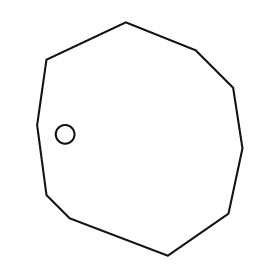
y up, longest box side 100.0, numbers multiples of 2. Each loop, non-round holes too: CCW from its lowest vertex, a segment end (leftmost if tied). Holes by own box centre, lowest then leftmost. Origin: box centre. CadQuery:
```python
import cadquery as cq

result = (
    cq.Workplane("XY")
    .moveTo(12.0, -50.0)
    .lineTo(38.0, -32.0)
    .lineTo(44.0, -4.0)
    .lineTo(40.0, 22.0)
    .lineTo(24.0, 38.0)
    .lineTo(-6.0, 50.0)
    .lineTo(-40.0, 34.0)
    .lineTo(-44.0, 6.0)
    .lineTo(-40.0, -24.0)
    .lineTo(-30.0, -34.0)
    .close()
    .moveTo(-32.0, 2.0)
    .circle(4.0)
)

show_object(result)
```